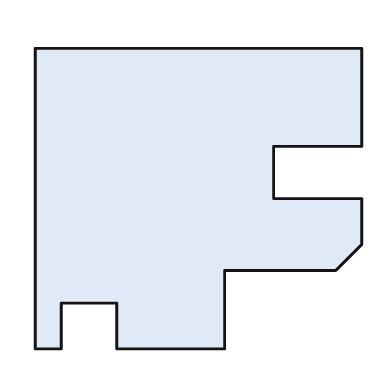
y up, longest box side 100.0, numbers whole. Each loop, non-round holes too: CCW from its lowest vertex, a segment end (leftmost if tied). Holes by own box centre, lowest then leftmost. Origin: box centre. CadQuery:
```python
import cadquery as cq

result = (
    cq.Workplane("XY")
    .moveTo(-50.0, -46.0)
    .lineTo(-42.0, -46.0)
    .lineTo(-42.0, -32.0)
    .lineTo(-25.0, -32.0)
    .lineTo(-25.0, -46.0)
    .lineTo(8.0, -46.0)
    .lineTo(8.0, -22.0)
    .lineTo(42.0, -22.0)
    .lineTo(50.0, -14.0)
    .lineTo(50.0, 0.0)
    .lineTo(23.0, 0.0)
    .lineTo(23.0, 16.0)
    .lineTo(50.0, 16.0)
    .lineTo(50.0, 46.0)
    .lineTo(-50.0, 46.0)
    .close()
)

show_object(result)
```